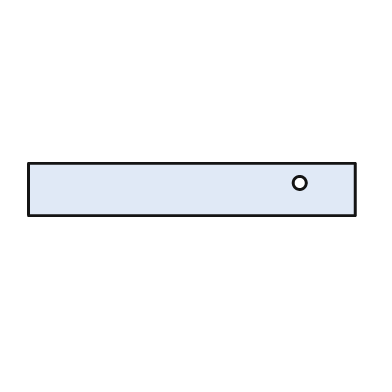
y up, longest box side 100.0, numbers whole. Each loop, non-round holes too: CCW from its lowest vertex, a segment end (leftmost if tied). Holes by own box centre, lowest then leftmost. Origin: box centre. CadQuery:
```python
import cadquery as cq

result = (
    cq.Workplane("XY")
    .moveTo(-50.0, -8.0)
    .lineTo(50.0, -8.0)
    .lineTo(50.0, 8.0)
    .lineTo(-50.0, 8.0)
    .close()
    .moveTo(33.0, 2.0)
    .circle(2.0)
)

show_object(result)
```